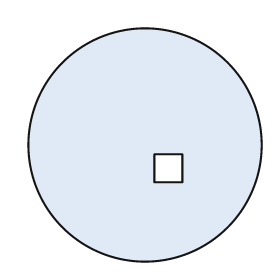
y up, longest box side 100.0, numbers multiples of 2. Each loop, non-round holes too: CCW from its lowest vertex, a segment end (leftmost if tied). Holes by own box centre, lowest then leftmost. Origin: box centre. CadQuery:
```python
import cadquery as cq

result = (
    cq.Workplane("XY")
    .moveTo(0.0, 0.0)
    .circle(50.0)
    .moveTo(4.0, -16.0)
    .lineTo(16.0, -16.0)
    .lineTo(16.0, -4.0)
    .lineTo(4.0, -4.0)
    .close()
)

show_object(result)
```